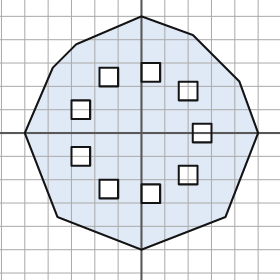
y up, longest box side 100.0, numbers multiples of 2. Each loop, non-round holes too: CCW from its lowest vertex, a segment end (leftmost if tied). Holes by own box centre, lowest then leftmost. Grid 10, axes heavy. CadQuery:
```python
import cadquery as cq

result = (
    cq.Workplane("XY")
    .moveTo(0.0, -50.0)
    .lineTo(36.0, -36.0)
    .lineTo(50.0, 0.0)
    .lineTo(42.0, 22.0)
    .lineTo(22.0, 42.0)
    .lineTo(0.0, 50.0)
    .lineTo(-28.0, 38.0)
    .lineTo(-38.0, 28.0)
    .lineTo(-50.0, 0.0)
    .lineTo(-36.0, -36.0)
    .close()
    .moveTo(0.0, -30.0)
    .lineTo(8.0, -30.0)
    .lineTo(8.0, -22.0)
    .lineTo(0.0, -22.0)
    .close()
    .moveTo(-18.0, -28.0)
    .lineTo(-10.0, -28.0)
    .lineTo(-10.0, -20.0)
    .lineTo(-18.0, -20.0)
    .close()
    .moveTo(16.0, -22.0)
    .lineTo(24.0, -22.0)
    .lineTo(24.0, -14.0)
    .lineTo(16.0, -14.0)
    .close()
    .moveTo(-30.0, -14.0)
    .lineTo(-22.0, -14.0)
    .lineTo(-22.0, -6.0)
    .lineTo(-30.0, -6.0)
    .close()
    .moveTo(22.0, -4.0)
    .lineTo(30.0, -4.0)
    .lineTo(30.0, 4.0)
    .lineTo(22.0, 4.0)
    .close()
    .moveTo(-30.0, 6.0)
    .lineTo(-22.0, 6.0)
    .lineTo(-22.0, 14.0)
    .lineTo(-30.0, 14.0)
    .close()
    .moveTo(16.0, 14.0)
    .lineTo(24.0, 14.0)
    .lineTo(24.0, 22.0)
    .lineTo(16.0, 22.0)
    .close()
    .moveTo(-18.0, 20.0)
    .lineTo(-10.0, 20.0)
    .lineTo(-10.0, 28.0)
    .lineTo(-18.0, 28.0)
    .close()
    .moveTo(0.0, 22.0)
    .lineTo(8.0, 22.0)
    .lineTo(8.0, 30.0)
    .lineTo(0.0, 30.0)
    .close()
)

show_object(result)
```